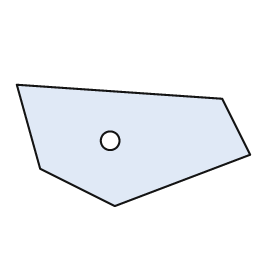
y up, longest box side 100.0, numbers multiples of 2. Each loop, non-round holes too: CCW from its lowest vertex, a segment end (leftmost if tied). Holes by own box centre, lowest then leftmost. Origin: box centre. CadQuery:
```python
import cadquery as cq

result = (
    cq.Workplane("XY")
    .moveTo(-8.0, -26.0)
    .lineTo(50.0, -4.0)
    .lineTo(38.0, 20.0)
    .lineTo(-50.0, 26.0)
    .lineTo(-40.0, -10.0)
    .close()
    .moveTo(-10.0, 2.0)
    .circle(4.0)
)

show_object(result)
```